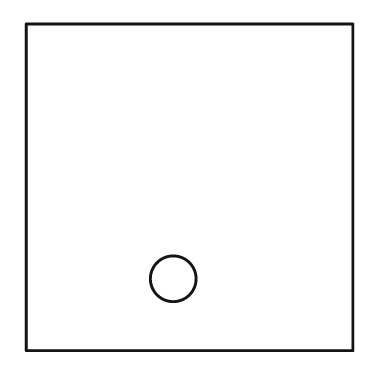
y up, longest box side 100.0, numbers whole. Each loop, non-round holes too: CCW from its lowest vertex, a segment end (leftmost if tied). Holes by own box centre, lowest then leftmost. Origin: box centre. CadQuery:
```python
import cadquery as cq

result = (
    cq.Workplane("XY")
    .moveTo(-50.0, -50.0)
    .lineTo(50.0, -50.0)
    .lineTo(50.0, 50.0)
    .lineTo(-50.0, 50.0)
    .close()
    .moveTo(-5.0, -28.0)
    .circle(7.0)
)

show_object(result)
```